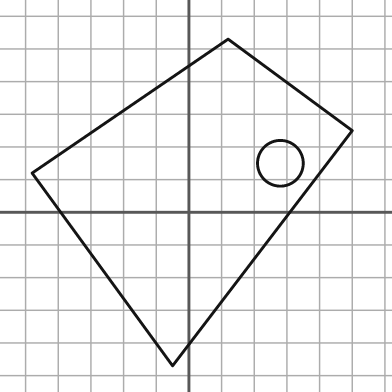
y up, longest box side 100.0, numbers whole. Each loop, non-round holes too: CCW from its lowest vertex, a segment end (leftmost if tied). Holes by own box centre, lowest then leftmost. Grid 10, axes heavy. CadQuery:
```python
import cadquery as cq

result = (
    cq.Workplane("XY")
    .moveTo(-5.0, -47.0)
    .lineTo(50.0, 25.0)
    .lineTo(12.0, 53.0)
    .lineTo(-48.0, 12.0)
    .close()
    .moveTo(28.0, 15.0)
    .circle(7.0)
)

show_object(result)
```